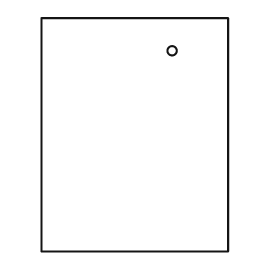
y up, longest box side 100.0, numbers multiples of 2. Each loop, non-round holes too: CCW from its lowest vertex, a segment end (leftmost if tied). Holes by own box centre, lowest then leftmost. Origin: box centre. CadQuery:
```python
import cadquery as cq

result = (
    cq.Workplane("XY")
    .moveTo(-40.0, -50.0)
    .lineTo(40.0, -50.0)
    .lineTo(40.0, 50.0)
    .lineTo(-40.0, 50.0)
    .close()
    .moveTo(16.0, 36.0)
    .circle(2.0)
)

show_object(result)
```